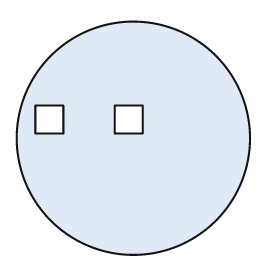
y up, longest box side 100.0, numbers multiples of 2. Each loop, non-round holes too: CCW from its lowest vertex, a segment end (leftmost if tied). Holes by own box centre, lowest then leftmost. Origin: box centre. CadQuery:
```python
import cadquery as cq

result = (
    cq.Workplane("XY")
    .moveTo(0.0, 0.0)
    .circle(50.0)
    .moveTo(-42.0, 2.0)
    .lineTo(-30.0, 2.0)
    .lineTo(-30.0, 14.0)
    .lineTo(-42.0, 14.0)
    .close()
    .moveTo(-8.0, 2.0)
    .lineTo(4.0, 2.0)
    .lineTo(4.0, 14.0)
    .lineTo(-8.0, 14.0)
    .close()
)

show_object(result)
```